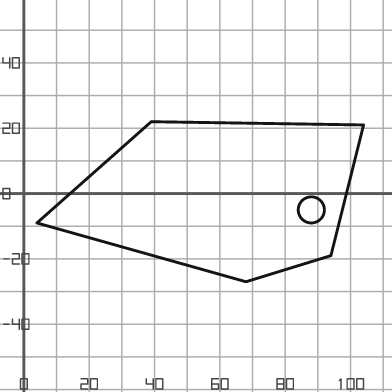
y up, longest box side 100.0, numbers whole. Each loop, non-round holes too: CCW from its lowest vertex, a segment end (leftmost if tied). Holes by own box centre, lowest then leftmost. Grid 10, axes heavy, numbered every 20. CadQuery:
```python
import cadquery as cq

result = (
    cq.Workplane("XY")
    .moveTo(68.0, -27.0)
    .lineTo(94.0, -19.0)
    .lineTo(104.0, 21.0)
    .lineTo(39.0, 22.0)
    .lineTo(4.0, -9.0)
    .close()
    .moveTo(88.0, -5.0)
    .circle(4.0)
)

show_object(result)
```